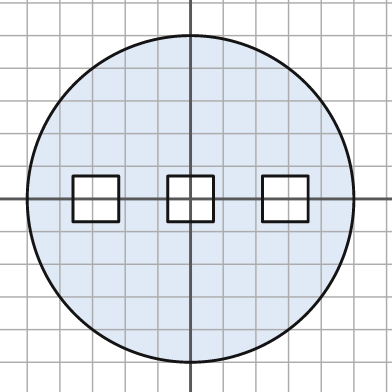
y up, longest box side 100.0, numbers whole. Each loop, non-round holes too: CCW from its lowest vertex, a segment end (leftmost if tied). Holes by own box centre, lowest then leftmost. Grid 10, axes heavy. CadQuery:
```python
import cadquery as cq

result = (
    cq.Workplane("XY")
    .moveTo(0.0, 0.0)
    .circle(50.0)
    .moveTo(-36.0, -7.0)
    .lineTo(-22.0, -7.0)
    .lineTo(-22.0, 7.0)
    .lineTo(-36.0, 7.0)
    .close()
    .moveTo(-7.0, -7.0)
    .lineTo(7.0, -7.0)
    .lineTo(7.0, 7.0)
    .lineTo(-7.0, 7.0)
    .close()
    .moveTo(22.0, -7.0)
    .lineTo(36.0, -7.0)
    .lineTo(36.0, 7.0)
    .lineTo(22.0, 7.0)
    .close()
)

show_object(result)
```